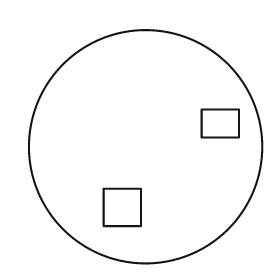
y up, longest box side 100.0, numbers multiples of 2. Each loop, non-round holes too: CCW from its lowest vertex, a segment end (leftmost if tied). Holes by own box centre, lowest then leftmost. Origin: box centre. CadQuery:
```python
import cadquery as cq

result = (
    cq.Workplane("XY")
    .moveTo(0.0, 0.0)
    .circle(50.0)
    .moveTo(-18.0, -34.0)
    .lineTo(-2.0, -34.0)
    .lineTo(-2.0, -18.0)
    .lineTo(-18.0, -18.0)
    .close()
    .moveTo(24.0, 4.0)
    .lineTo(40.0, 4.0)
    .lineTo(40.0, 16.0)
    .lineTo(24.0, 16.0)
    .close()
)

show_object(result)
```